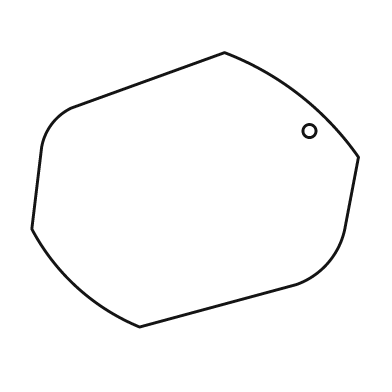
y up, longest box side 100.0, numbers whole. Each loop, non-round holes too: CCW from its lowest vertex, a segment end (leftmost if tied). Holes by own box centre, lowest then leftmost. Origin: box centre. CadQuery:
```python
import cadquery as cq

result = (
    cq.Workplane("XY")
    .moveTo(-17.0, -42.0)
    .lineTo(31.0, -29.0)
    .threePointArc((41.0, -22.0), (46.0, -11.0))
    .lineTo(50.0, 10.0)
    .threePointArc((32.0, 29.0), (9.0, 42.0))
    .lineTo(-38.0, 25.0)
    .threePointArc((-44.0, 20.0), (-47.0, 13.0))
    .lineTo(-50.0, -12.0)
    .threePointArc((-36.0, -30.0), (-17.0, -42.0))
    .close()
    .moveTo(35.0, 18.0)
    .circle(2.0)
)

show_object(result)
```